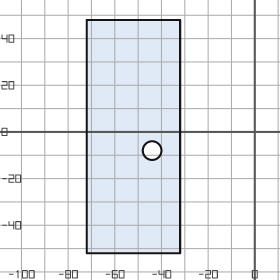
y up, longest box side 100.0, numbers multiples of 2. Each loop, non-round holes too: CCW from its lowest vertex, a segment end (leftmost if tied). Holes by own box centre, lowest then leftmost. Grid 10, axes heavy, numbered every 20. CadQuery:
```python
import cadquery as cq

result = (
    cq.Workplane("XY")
    .moveTo(-72.0, -52.0)
    .lineTo(-32.0, -52.0)
    .lineTo(-32.0, 48.0)
    .lineTo(-72.0, 48.0)
    .close()
    .moveTo(-44.0, -8.0)
    .circle(4.0)
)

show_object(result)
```